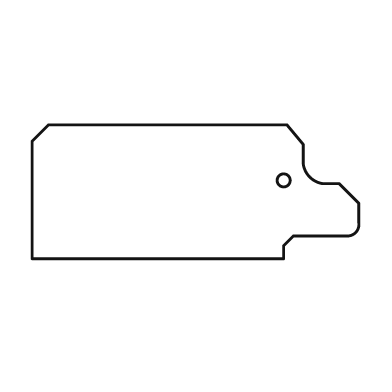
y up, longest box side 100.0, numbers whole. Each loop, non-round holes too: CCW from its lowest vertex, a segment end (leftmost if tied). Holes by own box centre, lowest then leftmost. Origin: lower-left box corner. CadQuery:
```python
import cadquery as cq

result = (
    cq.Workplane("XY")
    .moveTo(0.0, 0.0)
    .lineTo(77.0, 0.0)
    .lineTo(77.0, 4.0)
    .lineTo(80.0, 7.0)
    .lineTo(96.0, 7.0)
    .threePointArc((99.0, 8.0), (100.0, 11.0))
    .lineTo(100.0, 17.0)
    .lineTo(94.0, 23.0)
    .lineTo(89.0, 23.0)
    .threePointArc((85.0, 25.0), (83.0, 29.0))
    .lineTo(83.0, 35.0)
    .lineTo(78.0, 41.0)
    .lineTo(5.0, 41.0)
    .lineTo(0.0, 36.0)
    .close()
    .moveTo(77.0, 24.0)
    .circle(2.0)
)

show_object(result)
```